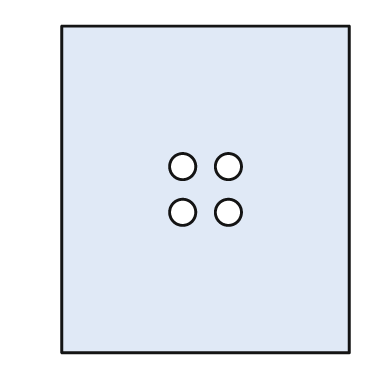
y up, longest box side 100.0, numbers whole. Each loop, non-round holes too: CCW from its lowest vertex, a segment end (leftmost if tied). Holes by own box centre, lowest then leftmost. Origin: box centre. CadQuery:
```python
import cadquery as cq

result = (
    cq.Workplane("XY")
    .moveTo(-44.0, -50.0)
    .lineTo(44.0, -50.0)
    .lineTo(44.0, 50.0)
    .lineTo(-44.0, 50.0)
    .close()
    .moveTo(-7.0, -7.0)
    .circle(4.0)
    .moveTo(7.0, -7.0)
    .circle(4.0)
    .moveTo(-7.0, 7.0)
    .circle(4.0)
    .moveTo(7.0, 7.0)
    .circle(4.0)
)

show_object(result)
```